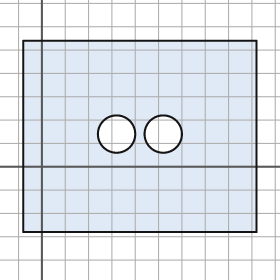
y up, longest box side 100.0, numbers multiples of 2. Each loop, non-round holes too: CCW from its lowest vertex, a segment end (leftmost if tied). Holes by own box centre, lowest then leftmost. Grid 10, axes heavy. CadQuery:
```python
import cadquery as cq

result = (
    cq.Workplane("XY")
    .moveTo(-8.0, -28.0)
    .lineTo(92.0, -28.0)
    .lineTo(92.0, 54.0)
    .lineTo(-8.0, 54.0)
    .close()
    .moveTo(32.0, 14.0)
    .circle(8.0)
    .moveTo(52.0, 14.0)
    .circle(8.0)
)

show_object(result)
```